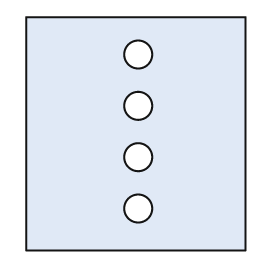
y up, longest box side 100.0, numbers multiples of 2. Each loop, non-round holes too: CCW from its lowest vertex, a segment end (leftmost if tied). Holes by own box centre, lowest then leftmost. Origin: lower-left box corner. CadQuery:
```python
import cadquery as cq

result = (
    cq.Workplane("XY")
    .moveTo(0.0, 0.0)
    .lineTo(94.0, 0.0)
    .lineTo(94.0, 100.0)
    .lineTo(0.0, 100.0)
    .close()
    .moveTo(48.0, 18.0)
    .circle(6.0)
    .moveTo(48.0, 40.0)
    .circle(6.0)
    .moveTo(48.0, 62.0)
    .circle(6.0)
    .moveTo(48.0, 84.0)
    .circle(6.0)
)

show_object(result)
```